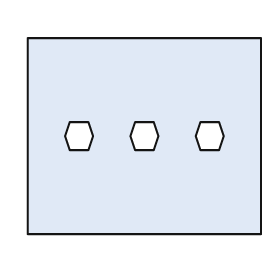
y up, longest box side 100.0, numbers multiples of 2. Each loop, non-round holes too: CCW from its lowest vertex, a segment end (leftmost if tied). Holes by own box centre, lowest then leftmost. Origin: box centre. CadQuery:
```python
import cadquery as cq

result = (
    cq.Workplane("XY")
    .moveTo(-50.0, -42.0)
    .lineTo(50.0, -42.0)
    .lineTo(50.0, 42.0)
    .lineTo(-50.0, 42.0)
    .close()
    .moveTo(-32.0, -6.0)
    .lineTo(-24.0, -6.0)
    .lineTo(-22.0, 0.0)
    .lineTo(-24.0, 6.0)
    .lineTo(-32.0, 6.0)
    .lineTo(-34.0, 0.0)
    .close()
    .moveTo(-4.0, -6.0)
    .lineTo(4.0, -6.0)
    .lineTo(6.0, 0.0)
    .lineTo(4.0, 6.0)
    .lineTo(-4.0, 6.0)
    .lineTo(-6.0, 0.0)
    .close()
    .moveTo(24.0, -6.0)
    .lineTo(32.0, -6.0)
    .lineTo(34.0, 0.0)
    .lineTo(32.0, 6.0)
    .lineTo(24.0, 6.0)
    .lineTo(22.0, 0.0)
    .close()
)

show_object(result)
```